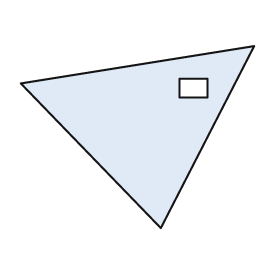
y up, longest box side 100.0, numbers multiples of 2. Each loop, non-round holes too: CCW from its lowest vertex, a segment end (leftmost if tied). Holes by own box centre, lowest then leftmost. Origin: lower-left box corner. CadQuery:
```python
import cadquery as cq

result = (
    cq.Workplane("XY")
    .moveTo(60.0, 0.0)
    .lineTo(100.0, 78.0)
    .lineTo(0.0, 62.0)
    .close()
    .moveTo(68.0, 56.0)
    .lineTo(80.0, 56.0)
    .lineTo(80.0, 64.0)
    .lineTo(68.0, 64.0)
    .close()
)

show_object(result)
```